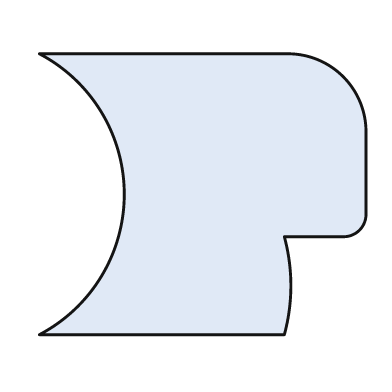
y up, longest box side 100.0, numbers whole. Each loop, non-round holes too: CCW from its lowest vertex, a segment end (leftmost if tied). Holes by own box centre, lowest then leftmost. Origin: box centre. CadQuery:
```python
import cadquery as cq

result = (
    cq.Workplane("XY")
    .moveTo(-50.0, -43.0)
    .lineTo(25.0, -43.0)
    .threePointArc((27.0, -28.0), (25.0, -13.0))
    .lineTo(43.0, -13.0)
    .threePointArc((48.0, -11.0), (50.0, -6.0))
    .lineTo(50.0, 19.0)
    .threePointArc((43.0, 36.0), (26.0, 43.0))
    .lineTo(-50.0, 43.0)
    .threePointArc((-24.0, 0.0), (-50.0, -43.0))
    .close()
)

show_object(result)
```